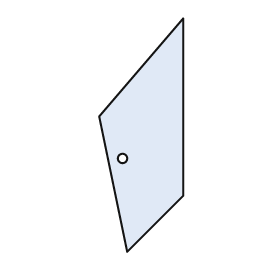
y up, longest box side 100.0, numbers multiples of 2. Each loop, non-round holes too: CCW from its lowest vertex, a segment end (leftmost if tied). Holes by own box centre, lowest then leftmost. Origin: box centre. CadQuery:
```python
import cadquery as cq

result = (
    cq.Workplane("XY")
    .moveTo(-6.0, -50.0)
    .lineTo(18.0, -26.0)
    .lineTo(18.0, 50.0)
    .lineTo(-18.0, 8.0)
    .close()
    .moveTo(-8.0, -10.0)
    .circle(2.0)
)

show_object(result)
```